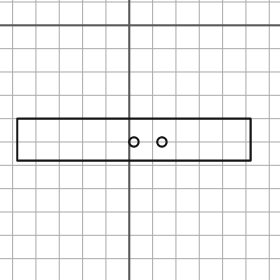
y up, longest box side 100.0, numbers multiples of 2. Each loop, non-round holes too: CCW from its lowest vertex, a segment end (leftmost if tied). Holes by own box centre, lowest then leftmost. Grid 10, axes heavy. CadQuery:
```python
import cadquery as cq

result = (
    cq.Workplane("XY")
    .moveTo(-48.0, -58.0)
    .lineTo(52.0, -58.0)
    .lineTo(52.0, -40.0)
    .lineTo(-48.0, -40.0)
    .close()
    .moveTo(2.0, -50.0)
    .circle(2.0)
    .moveTo(14.0, -50.0)
    .circle(2.0)
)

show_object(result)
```